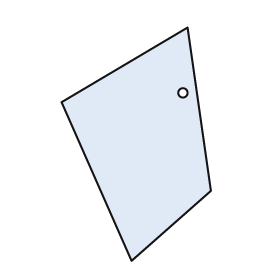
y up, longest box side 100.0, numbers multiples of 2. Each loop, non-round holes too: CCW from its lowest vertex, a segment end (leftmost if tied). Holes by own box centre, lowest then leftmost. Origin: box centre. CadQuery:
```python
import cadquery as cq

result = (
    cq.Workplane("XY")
    .moveTo(-2.0, -50.0)
    .lineTo(32.0, -20.0)
    .lineTo(22.0, 50.0)
    .lineTo(-32.0, 18.0)
    .close()
    .moveTo(20.0, 22.0)
    .circle(2.0)
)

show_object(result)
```